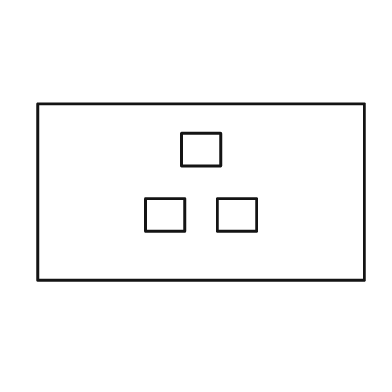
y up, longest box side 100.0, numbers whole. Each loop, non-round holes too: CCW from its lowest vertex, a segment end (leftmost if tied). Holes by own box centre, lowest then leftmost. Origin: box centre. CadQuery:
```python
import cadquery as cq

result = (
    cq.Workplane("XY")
    .moveTo(-50.0, -27.0)
    .lineTo(50.0, -27.0)
    .lineTo(50.0, 27.0)
    .lineTo(-50.0, 27.0)
    .close()
    .moveTo(-17.0, -12.0)
    .lineTo(-5.0, -12.0)
    .lineTo(-5.0, -2.0)
    .lineTo(-17.0, -2.0)
    .close()
    .moveTo(5.0, -12.0)
    .lineTo(17.0, -12.0)
    .lineTo(17.0, -2.0)
    .lineTo(5.0, -2.0)
    .close()
    .moveTo(-6.0, 8.0)
    .lineTo(6.0, 8.0)
    .lineTo(6.0, 18.0)
    .lineTo(-6.0, 18.0)
    .close()
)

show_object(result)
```